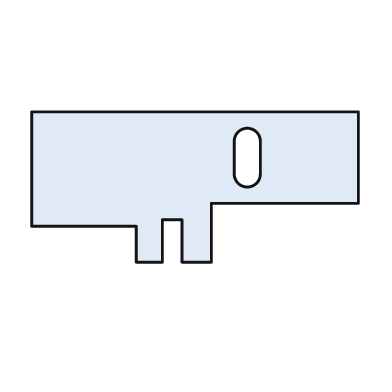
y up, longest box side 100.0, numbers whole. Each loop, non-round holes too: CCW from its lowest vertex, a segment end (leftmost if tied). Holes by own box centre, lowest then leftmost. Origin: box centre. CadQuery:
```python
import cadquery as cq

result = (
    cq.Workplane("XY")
    .moveTo(-18.0, -23.0)
    .lineTo(-10.0, -23.0)
    .lineTo(-10.0, -10.0)
    .lineTo(-4.0, -10.0)
    .lineTo(-4.0, -23.0)
    .lineTo(5.0, -23.0)
    .lineTo(5.0, -5.0)
    .lineTo(50.0, -5.0)
    .lineTo(50.0, 23.0)
    .lineTo(-50.0, 23.0)
    .lineTo(-50.0, -12.0)
    .lineTo(-18.0, -12.0)
    .close()
    .moveTo(12.0, 4.0)
    .threePointArc((16.0, 0.0), (20.0, 4.0))
    .lineTo(20.0, 14.0)
    .threePointArc((16.0, 18.0), (12.0, 14.0))
    .close()
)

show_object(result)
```